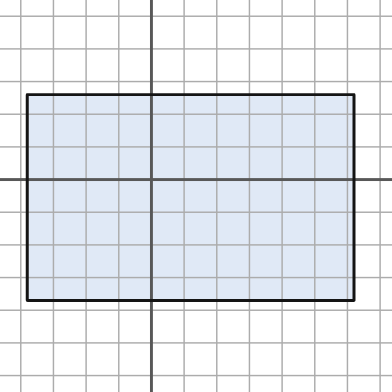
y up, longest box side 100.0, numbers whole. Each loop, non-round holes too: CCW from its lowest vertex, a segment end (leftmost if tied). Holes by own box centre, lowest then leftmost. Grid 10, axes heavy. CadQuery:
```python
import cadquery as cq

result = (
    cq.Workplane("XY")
    .moveTo(-38.0, -37.0)
    .lineTo(62.0, -37.0)
    .lineTo(62.0, 26.0)
    .lineTo(-38.0, 26.0)
    .close()
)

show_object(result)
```